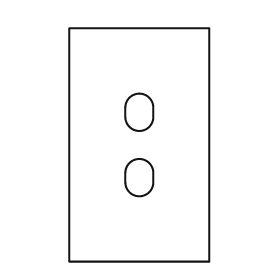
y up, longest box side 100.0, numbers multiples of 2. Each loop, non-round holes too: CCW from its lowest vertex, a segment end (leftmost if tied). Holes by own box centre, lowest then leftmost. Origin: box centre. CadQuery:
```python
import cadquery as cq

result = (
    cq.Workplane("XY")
    .moveTo(-30.0, -50.0)
    .lineTo(30.0, -50.0)
    .lineTo(30.0, 50.0)
    .lineTo(-30.0, 50.0)
    .close()
    .moveTo(-6.0, -16.0)
    .threePointArc((0.0, -22.0), (6.0, -16.0))
    .lineTo(6.0, -12.0)
    .threePointArc((0.0, -6.0), (-6.0, -12.0))
    .close()
    .moveTo(-6.0, 12.0)
    .threePointArc((0.0, 6.0), (6.0, 12.0))
    .lineTo(6.0, 16.0)
    .threePointArc((0.0, 22.0), (-6.0, 16.0))
    .close()
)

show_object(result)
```